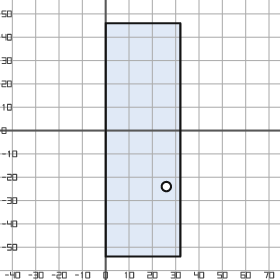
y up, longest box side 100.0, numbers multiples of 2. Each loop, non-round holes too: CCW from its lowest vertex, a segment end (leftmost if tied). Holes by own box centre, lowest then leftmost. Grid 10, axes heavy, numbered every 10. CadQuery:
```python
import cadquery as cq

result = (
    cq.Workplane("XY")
    .moveTo(0.0, -54.0)
    .lineTo(32.0, -54.0)
    .lineTo(32.0, 46.0)
    .lineTo(0.0, 46.0)
    .close()
    .moveTo(26.0, -24.0)
    .circle(2.0)
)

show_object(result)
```